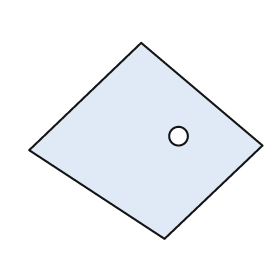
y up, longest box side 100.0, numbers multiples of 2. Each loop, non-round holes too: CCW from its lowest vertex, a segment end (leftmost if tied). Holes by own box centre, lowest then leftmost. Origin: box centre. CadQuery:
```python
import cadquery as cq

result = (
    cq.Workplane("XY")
    .moveTo(8.0, -42.0)
    .lineTo(50.0, -2.0)
    .lineTo(-2.0, 42.0)
    .lineTo(-50.0, -4.0)
    .close()
    .moveTo(14.0, 2.0)
    .circle(4.0)
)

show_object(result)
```